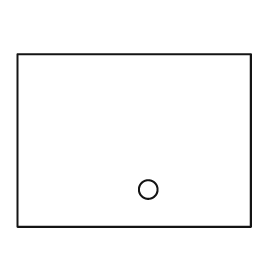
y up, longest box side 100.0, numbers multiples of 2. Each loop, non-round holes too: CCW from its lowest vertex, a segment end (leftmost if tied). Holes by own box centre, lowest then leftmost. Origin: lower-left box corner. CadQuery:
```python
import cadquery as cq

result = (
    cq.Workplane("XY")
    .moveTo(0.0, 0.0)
    .lineTo(100.0, 0.0)
    .lineTo(100.0, 74.0)
    .lineTo(0.0, 74.0)
    .close()
    .moveTo(56.0, 16.0)
    .circle(4.0)
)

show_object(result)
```